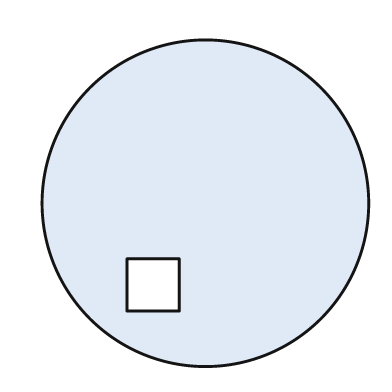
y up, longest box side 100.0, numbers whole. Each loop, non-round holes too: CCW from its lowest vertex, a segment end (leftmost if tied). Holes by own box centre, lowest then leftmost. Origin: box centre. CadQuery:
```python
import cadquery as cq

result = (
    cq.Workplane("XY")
    .moveTo(0.0, 0.0)
    .circle(50.0)
    .moveTo(-24.0, -33.0)
    .lineTo(-8.0, -33.0)
    .lineTo(-8.0, -17.0)
    .lineTo(-24.0, -17.0)
    .close()
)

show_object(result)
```